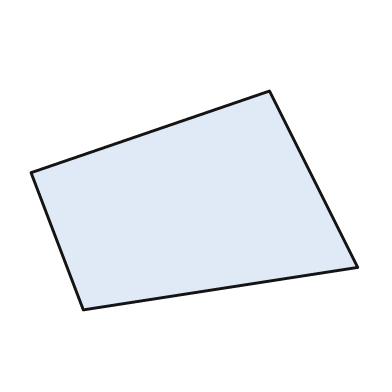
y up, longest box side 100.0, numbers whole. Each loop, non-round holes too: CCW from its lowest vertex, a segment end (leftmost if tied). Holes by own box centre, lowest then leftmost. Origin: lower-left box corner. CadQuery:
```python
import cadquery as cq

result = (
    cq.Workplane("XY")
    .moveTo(16.0, 0.0)
    .lineTo(100.0, 13.0)
    .lineTo(73.0, 67.0)
    .lineTo(0.0, 42.0)
    .close()
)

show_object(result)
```